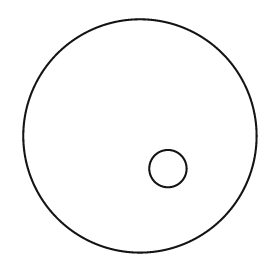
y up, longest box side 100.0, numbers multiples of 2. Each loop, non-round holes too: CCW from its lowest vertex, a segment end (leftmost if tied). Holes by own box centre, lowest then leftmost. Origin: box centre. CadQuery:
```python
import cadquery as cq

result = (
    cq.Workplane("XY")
    .moveTo(0.0, 0.0)
    .circle(50.0)
    .moveTo(12.0, -14.0)
    .circle(8.0)
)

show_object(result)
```